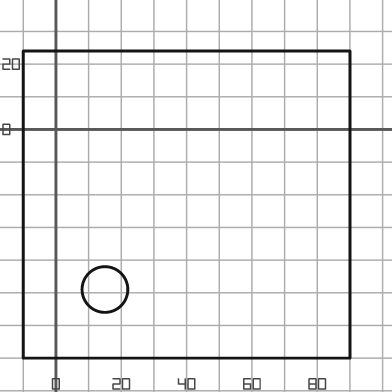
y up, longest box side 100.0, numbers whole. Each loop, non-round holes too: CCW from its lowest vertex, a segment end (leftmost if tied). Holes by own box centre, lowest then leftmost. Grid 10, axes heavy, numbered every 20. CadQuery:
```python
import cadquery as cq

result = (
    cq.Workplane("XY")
    .moveTo(-10.0, -70.0)
    .lineTo(90.0, -70.0)
    .lineTo(90.0, 24.0)
    .lineTo(-10.0, 24.0)
    .close()
    .moveTo(15.0, -49.0)
    .circle(7.0)
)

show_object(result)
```